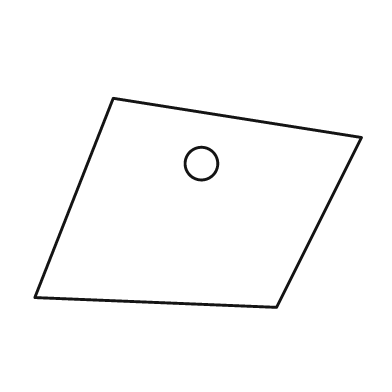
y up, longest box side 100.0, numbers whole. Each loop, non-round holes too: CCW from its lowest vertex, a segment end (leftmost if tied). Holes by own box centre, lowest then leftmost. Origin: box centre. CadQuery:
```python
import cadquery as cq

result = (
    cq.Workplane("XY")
    .moveTo(24.0, -32.0)
    .lineTo(50.0, 20.0)
    .lineTo(-26.0, 32.0)
    .lineTo(-50.0, -29.0)
    .close()
    .moveTo(1.0, 12.0)
    .circle(5.0)
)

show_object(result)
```